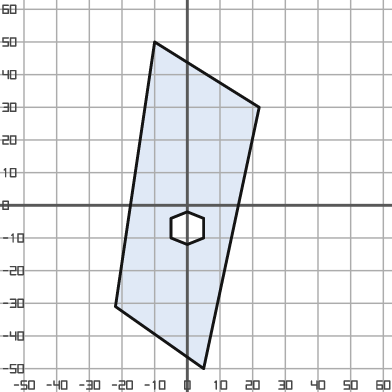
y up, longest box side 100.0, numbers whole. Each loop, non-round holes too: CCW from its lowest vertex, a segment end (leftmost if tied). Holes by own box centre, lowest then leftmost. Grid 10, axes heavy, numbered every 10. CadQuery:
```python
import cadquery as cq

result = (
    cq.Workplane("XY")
    .moveTo(5.0, -50.0)
    .lineTo(22.0, 30.0)
    .lineTo(-10.0, 50.0)
    .lineTo(-22.0, -31.0)
    .close()
    .moveTo(0.0, -12.0)
    .lineTo(5.0, -10.0)
    .lineTo(5.0, -4.0)
    .lineTo(0.0, -2.0)
    .lineTo(-5.0, -4.0)
    .lineTo(-5.0, -10.0)
    .close()
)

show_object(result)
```